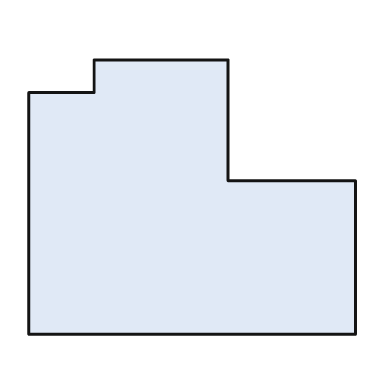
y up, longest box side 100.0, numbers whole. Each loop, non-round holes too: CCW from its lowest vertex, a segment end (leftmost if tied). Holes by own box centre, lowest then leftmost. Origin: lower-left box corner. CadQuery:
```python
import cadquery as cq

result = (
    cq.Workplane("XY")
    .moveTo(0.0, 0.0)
    .lineTo(100.0, 0.0)
    .lineTo(100.0, 47.0)
    .lineTo(61.0, 47.0)
    .lineTo(61.0, 84.0)
    .lineTo(20.0, 84.0)
    .lineTo(20.0, 74.0)
    .lineTo(0.0, 74.0)
    .close()
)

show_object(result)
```